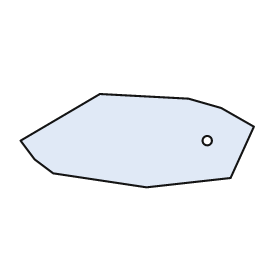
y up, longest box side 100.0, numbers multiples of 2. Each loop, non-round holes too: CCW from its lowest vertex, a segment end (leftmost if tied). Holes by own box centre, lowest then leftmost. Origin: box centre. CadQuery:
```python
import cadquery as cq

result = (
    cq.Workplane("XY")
    .moveTo(4.0, -20.0)
    .lineTo(40.0, -16.0)
    .lineTo(50.0, 6.0)
    .lineTo(36.0, 14.0)
    .lineTo(22.0, 18.0)
    .lineTo(-16.0, 20.0)
    .lineTo(-50.0, 0.0)
    .lineTo(-44.0, -8.0)
    .lineTo(-36.0, -14.0)
    .close()
    .moveTo(30.0, 0.0)
    .circle(2.0)
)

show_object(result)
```